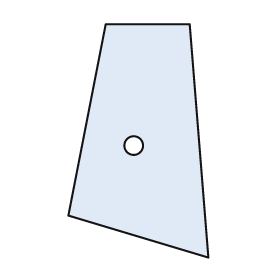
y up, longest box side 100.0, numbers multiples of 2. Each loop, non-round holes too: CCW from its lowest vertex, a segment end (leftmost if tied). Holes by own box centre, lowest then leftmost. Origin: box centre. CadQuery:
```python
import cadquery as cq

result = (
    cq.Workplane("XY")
    .moveTo(30.0, -50.0)
    .lineTo(22.0, 50.0)
    .lineTo(-14.0, 50.0)
    .lineTo(-30.0, -32.0)
    .close()
    .moveTo(-2.0, -2.0)
    .circle(4.0)
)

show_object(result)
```